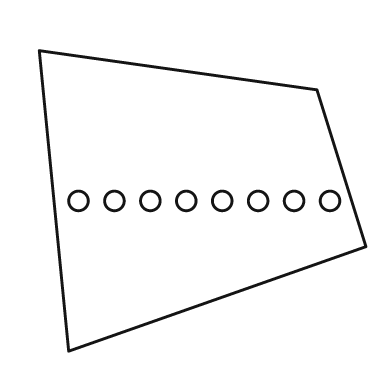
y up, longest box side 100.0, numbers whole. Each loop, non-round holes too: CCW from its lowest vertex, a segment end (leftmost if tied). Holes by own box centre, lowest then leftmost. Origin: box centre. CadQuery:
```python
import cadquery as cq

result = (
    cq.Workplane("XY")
    .moveTo(-41.0, -46.0)
    .lineTo(50.0, -14.0)
    .lineTo(35.0, 34.0)
    .lineTo(-50.0, 46.0)
    .close()
    .moveTo(-38.0, 0.0)
    .circle(3.0)
    .moveTo(-27.0, 0.0)
    .circle(3.0)
    .moveTo(-16.0, 0.0)
    .circle(3.0)
    .moveTo(-5.0, 0.0)
    .circle(3.0)
    .moveTo(6.0, 0.0)
    .circle(3.0)
    .moveTo(17.0, 0.0)
    .circle(3.0)
    .moveTo(28.0, 0.0)
    .circle(3.0)
    .moveTo(39.0, 0.0)
    .circle(3.0)
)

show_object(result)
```